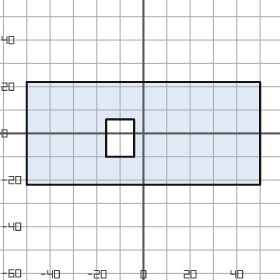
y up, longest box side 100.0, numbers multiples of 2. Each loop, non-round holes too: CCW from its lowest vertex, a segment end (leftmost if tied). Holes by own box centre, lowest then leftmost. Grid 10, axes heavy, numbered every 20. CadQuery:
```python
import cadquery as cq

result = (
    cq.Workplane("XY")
    .moveTo(-50.0, -22.0)
    .lineTo(50.0, -22.0)
    .lineTo(50.0, 22.0)
    .lineTo(-50.0, 22.0)
    .close()
    .moveTo(-16.0, -10.0)
    .lineTo(-4.0, -10.0)
    .lineTo(-4.0, 6.0)
    .lineTo(-16.0, 6.0)
    .close()
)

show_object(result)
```